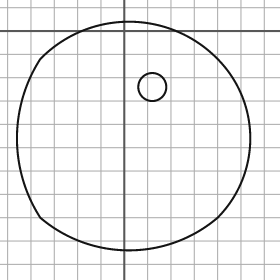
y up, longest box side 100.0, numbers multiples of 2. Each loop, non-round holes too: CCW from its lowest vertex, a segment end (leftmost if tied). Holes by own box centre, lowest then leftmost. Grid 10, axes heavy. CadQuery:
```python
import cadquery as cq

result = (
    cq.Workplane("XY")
    .moveTo(-36.0, -80.0)
    .threePointArc((2.0, -94.0), (40.0, -80.0))
    .threePointArc((54.0, -46.0), (40.0, -12.0))
    .threePointArc((2.0, 4.0), (-36.0, -12.0))
    .threePointArc((-46.0, -46.0), (-36.0, -80.0))
    .close()
    .moveTo(12.0, -24.0)
    .circle(6.0)
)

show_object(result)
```